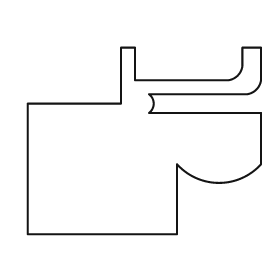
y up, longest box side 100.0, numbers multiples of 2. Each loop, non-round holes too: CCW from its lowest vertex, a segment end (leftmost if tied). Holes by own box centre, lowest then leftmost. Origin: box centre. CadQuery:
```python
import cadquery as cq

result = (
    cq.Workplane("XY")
    .moveTo(-50.0, -40.0)
    .lineTo(14.0, -40.0)
    .lineTo(14.0, -10.0)
    .threePointArc((32.0, -18.0), (50.0, -10.0))
    .lineTo(50.0, 12.0)
    .lineTo(2.0, 12.0)
    .threePointArc((4.0, 16.0), (2.0, 20.0))
    .lineTo(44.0, 20.0)
    .threePointArc((48.0, 22.0), (50.0, 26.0))
    .lineTo(50.0, 40.0)
    .lineTo(42.0, 40.0)
    .lineTo(42.0, 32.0)
    .threePointArc((40.0, 28.0), (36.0, 26.0))
    .lineTo(-4.0, 26.0)
    .lineTo(-4.0, 40.0)
    .lineTo(-10.0, 40.0)
    .lineTo(-10.0, 16.0)
    .lineTo(-50.0, 16.0)
    .close()
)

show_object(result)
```